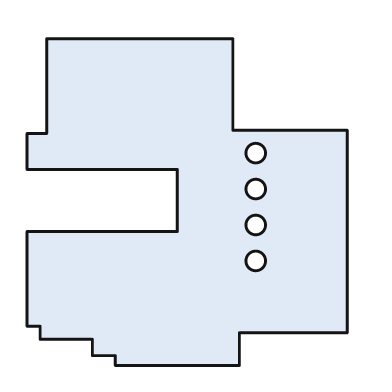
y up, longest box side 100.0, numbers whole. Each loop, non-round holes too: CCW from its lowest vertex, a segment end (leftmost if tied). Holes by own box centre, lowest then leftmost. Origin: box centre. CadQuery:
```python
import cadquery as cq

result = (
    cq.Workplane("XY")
    .moveTo(-22.0, -50.0)
    .lineTo(16.0, -50.0)
    .lineTo(16.0, -40.0)
    .lineTo(49.0, -40.0)
    .lineTo(49.0, 22.0)
    .lineTo(14.0, 22.0)
    .lineTo(14.0, 50.0)
    .lineTo(-43.0, 50.0)
    .lineTo(-43.0, 21.0)
    .lineTo(-49.0, 21.0)
    .lineTo(-49.0, 10.0)
    .lineTo(-3.0, 10.0)
    .lineTo(-3.0, -9.0)
    .lineTo(-49.0, -9.0)
    .lineTo(-49.0, -38.0)
    .lineTo(-45.0, -38.0)
    .lineTo(-45.0, -42.0)
    .lineTo(-29.0, -42.0)
    .lineTo(-29.0, -47.0)
    .lineTo(-22.0, -47.0)
    .close()
    .moveTo(21.0, -18.0)
    .circle(3.0)
    .moveTo(21.0, -7.0)
    .circle(3.0)
    .moveTo(21.0, 4.0)
    .circle(3.0)
    .moveTo(21.0, 15.0)
    .circle(3.0)
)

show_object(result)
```